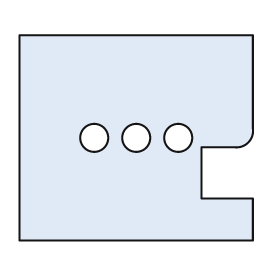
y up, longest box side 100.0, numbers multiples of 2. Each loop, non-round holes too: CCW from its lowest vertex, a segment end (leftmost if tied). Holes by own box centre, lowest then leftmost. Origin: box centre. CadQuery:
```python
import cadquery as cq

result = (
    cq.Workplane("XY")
    .moveTo(-50.0, -44.0)
    .lineTo(50.0, -44.0)
    .lineTo(50.0, -26.0)
    .lineTo(28.0, -26.0)
    .lineTo(28.0, -4.0)
    .lineTo(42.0, -4.0)
    .threePointArc((48.0, -2.0), (50.0, 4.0))
    .lineTo(50.0, 44.0)
    .lineTo(-50.0, 44.0)
    .close()
    .moveTo(-18.0, 0.0)
    .circle(6.0)
    .moveTo(0.0, 0.0)
    .circle(6.0)
    .moveTo(18.0, 0.0)
    .circle(6.0)
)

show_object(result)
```